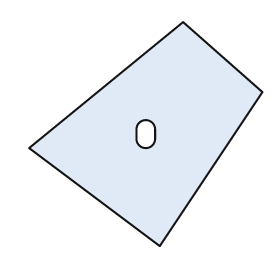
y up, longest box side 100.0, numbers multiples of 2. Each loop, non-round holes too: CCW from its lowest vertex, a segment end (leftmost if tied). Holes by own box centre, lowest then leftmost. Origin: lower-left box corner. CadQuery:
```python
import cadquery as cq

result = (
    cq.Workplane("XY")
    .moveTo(56.0, 0.0)
    .lineTo(100.0, 66.0)
    .lineTo(66.0, 96.0)
    .lineTo(0.0, 42.0)
    .close()
    .moveTo(46.0, 46.0)
    .threePointArc((50.0, 42.0), (54.0, 46.0))
    .lineTo(54.0, 50.0)
    .threePointArc((50.0, 54.0), (46.0, 50.0))
    .close()
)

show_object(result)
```